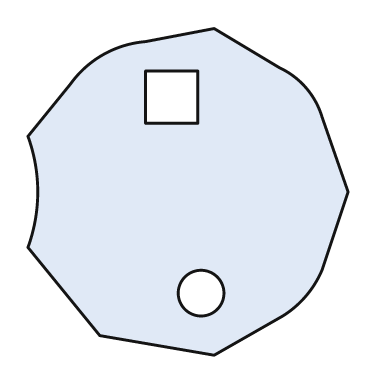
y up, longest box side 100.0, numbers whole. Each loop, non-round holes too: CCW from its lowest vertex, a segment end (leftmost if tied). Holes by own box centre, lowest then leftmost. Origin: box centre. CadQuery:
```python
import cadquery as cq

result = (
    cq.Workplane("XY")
    .moveTo(8.0, -50.0)
    .lineTo(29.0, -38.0)
    .threePointArc((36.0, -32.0), (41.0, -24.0))
    .lineTo(49.0, 0.0)
    .lineTo(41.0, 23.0)
    .threePointArc((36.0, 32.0), (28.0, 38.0))
    .lineTo(8.0, 50.0)
    .lineTo(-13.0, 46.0)
    .threePointArc((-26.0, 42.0), (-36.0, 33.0))
    .lineTo(-49.0, 17.0)
    .threePointArc((-46.0, 0.0), (-49.0, -17.0))
    .lineTo(-27.0, -44.0)
    .close()
    .moveTo(4.0, -31.0)
    .circle(7.0)
    .moveTo(-13.0, 21.0)
    .lineTo(3.0, 21.0)
    .lineTo(3.0, 37.0)
    .lineTo(-13.0, 37.0)
    .close()
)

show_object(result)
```